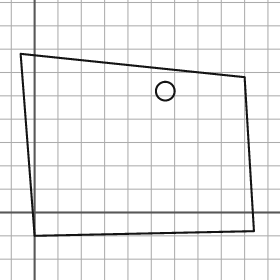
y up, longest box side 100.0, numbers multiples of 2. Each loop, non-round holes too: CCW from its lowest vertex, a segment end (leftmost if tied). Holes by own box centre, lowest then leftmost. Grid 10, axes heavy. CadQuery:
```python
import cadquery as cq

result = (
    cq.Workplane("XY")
    .moveTo(0.0, -10.0)
    .lineTo(94.0, -8.0)
    .lineTo(90.0, 58.0)
    .lineTo(-6.0, 68.0)
    .close()
    .moveTo(56.0, 52.0)
    .circle(4.0)
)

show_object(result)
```